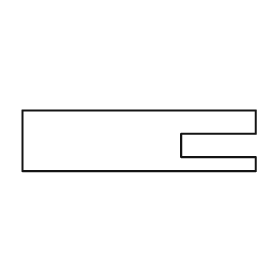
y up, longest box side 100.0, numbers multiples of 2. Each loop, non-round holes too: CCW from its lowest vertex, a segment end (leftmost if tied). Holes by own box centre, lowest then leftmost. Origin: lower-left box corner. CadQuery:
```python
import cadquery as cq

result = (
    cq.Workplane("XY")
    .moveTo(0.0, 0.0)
    .lineTo(100.0, 0.0)
    .lineTo(100.0, 6.0)
    .lineTo(68.0, 6.0)
    .lineTo(68.0, 16.0)
    .lineTo(100.0, 16.0)
    .lineTo(100.0, 26.0)
    .lineTo(0.0, 26.0)
    .close()
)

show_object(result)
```